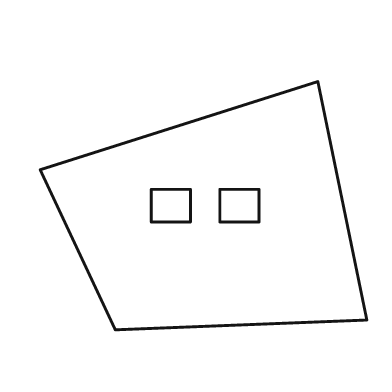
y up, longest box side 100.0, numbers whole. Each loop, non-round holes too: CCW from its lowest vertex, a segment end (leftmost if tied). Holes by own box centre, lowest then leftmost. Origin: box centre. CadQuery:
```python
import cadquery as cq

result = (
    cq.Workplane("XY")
    .moveTo(-27.0, -38.0)
    .lineTo(50.0, -35.0)
    .lineTo(35.0, 38.0)
    .lineTo(-50.0, 11.0)
    .close()
    .moveTo(-16.0, -5.0)
    .lineTo(-4.0, -5.0)
    .lineTo(-4.0, 5.0)
    .lineTo(-16.0, 5.0)
    .close()
    .moveTo(5.0, -5.0)
    .lineTo(17.0, -5.0)
    .lineTo(17.0, 5.0)
    .lineTo(5.0, 5.0)
    .close()
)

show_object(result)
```